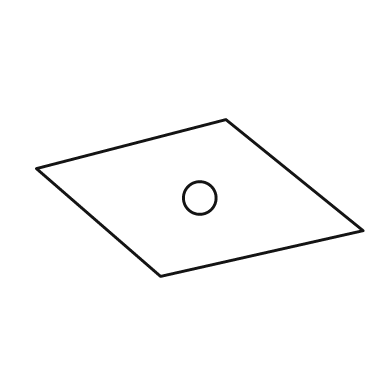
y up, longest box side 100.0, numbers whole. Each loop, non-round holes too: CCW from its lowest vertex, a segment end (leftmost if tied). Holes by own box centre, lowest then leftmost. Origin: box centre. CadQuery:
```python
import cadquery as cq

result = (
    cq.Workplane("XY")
    .moveTo(-12.0, -24.0)
    .lineTo(50.0, -10.0)
    .lineTo(8.0, 24.0)
    .lineTo(-50.0, 9.0)
    .close()
    .moveTo(0.0, 0.0)
    .circle(5.0)
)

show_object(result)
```